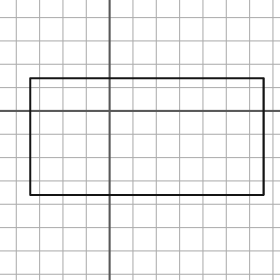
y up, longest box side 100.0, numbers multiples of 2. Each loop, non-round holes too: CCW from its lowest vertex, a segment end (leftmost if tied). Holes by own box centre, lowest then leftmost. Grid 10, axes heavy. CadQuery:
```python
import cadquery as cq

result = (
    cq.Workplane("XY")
    .moveTo(-34.0, -36.0)
    .lineTo(66.0, -36.0)
    .lineTo(66.0, 14.0)
    .lineTo(-34.0, 14.0)
    .close()
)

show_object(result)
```